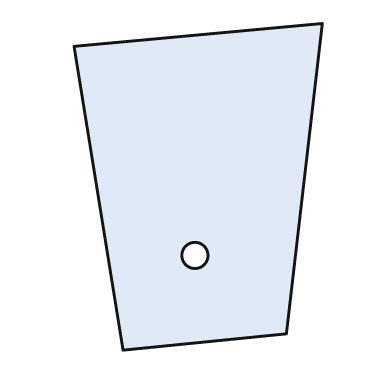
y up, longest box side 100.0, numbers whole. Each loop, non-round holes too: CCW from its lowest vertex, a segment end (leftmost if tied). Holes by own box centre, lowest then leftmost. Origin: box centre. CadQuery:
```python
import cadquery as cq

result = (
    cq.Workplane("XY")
    .moveTo(-23.0, -50.0)
    .lineTo(27.0, -45.0)
    .lineTo(38.0, 50.0)
    .lineTo(-38.0, 43.0)
    .close()
    .moveTo(-1.0, -21.0)
    .circle(4.0)
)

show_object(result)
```